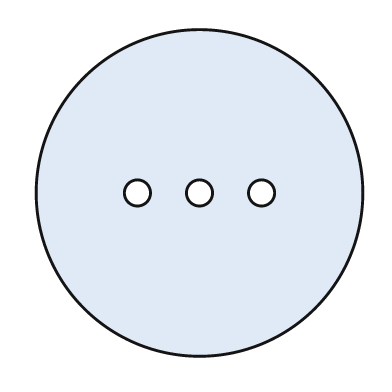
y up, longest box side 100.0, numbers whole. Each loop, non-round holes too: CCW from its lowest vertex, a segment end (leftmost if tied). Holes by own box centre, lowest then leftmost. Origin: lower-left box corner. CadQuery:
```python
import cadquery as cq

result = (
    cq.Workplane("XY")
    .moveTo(50.0, 50.0)
    .circle(50.0)
    .moveTo(31.0, 50.0)
    .circle(4.0)
    .moveTo(50.0, 50.0)
    .circle(4.0)
    .moveTo(69.0, 50.0)
    .circle(4.0)
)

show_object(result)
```